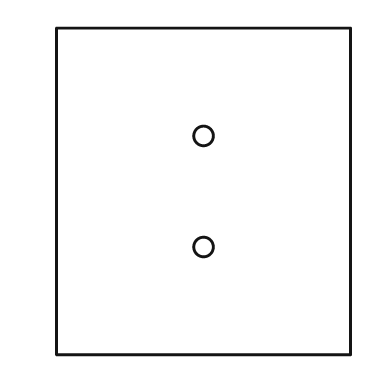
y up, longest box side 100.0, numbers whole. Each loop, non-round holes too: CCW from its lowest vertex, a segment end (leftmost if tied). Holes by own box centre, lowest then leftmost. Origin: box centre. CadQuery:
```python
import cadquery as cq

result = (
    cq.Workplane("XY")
    .moveTo(-45.0, -50.0)
    .lineTo(45.0, -50.0)
    .lineTo(45.0, 50.0)
    .lineTo(-45.0, 50.0)
    .close()
    .moveTo(0.0, -17.0)
    .circle(3.0)
    .moveTo(0.0, 17.0)
    .circle(3.0)
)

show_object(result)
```